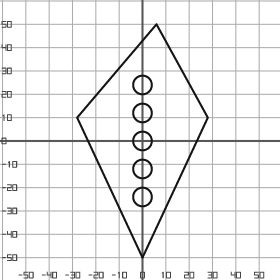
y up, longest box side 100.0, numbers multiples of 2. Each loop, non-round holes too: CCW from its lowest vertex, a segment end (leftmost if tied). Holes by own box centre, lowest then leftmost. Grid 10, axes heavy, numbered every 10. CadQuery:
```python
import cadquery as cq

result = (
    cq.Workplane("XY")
    .moveTo(0.0, -50.0)
    .lineTo(28.0, 10.0)
    .lineTo(6.0, 50.0)
    .lineTo(-28.0, 10.0)
    .close()
    .moveTo(0.0, -24.0)
    .circle(4.0)
    .moveTo(0.0, -12.0)
    .circle(4.0)
    .moveTo(0.0, 0.0)
    .circle(4.0)
    .moveTo(0.0, 12.0)
    .circle(4.0)
    .moveTo(0.0, 24.0)
    .circle(4.0)
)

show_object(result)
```